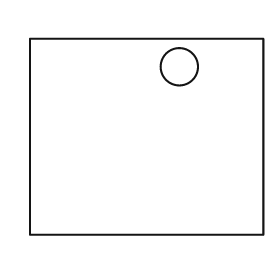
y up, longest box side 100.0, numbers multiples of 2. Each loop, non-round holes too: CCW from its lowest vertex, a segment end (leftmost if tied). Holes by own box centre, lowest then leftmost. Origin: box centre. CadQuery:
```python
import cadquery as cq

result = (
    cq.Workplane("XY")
    .moveTo(-50.0, -42.0)
    .lineTo(50.0, -42.0)
    .lineTo(50.0, 42.0)
    .lineTo(-50.0, 42.0)
    .close()
    .moveTo(14.0, 30.0)
    .circle(8.0)
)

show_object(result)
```